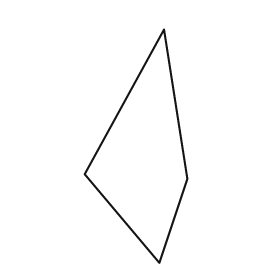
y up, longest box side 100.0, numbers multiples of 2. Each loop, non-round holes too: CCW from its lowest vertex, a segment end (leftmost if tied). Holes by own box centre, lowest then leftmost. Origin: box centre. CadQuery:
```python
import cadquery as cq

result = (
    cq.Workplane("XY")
    .moveTo(10.0, -50.0)
    .lineTo(22.0, -14.0)
    .lineTo(12.0, 50.0)
    .lineTo(-22.0, -12.0)
    .close()
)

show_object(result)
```